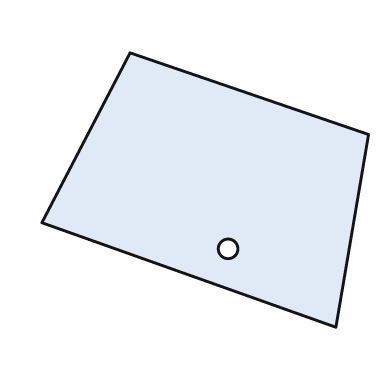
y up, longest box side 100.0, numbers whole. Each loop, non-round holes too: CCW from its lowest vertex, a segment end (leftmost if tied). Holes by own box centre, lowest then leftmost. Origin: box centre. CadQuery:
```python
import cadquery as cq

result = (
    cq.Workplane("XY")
    .moveTo(40.0, -42.0)
    .lineTo(50.0, 17.0)
    .lineTo(-23.0, 42.0)
    .lineTo(-50.0, -10.0)
    .close()
    .moveTo(7.0, -18.0)
    .circle(3.0)
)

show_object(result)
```